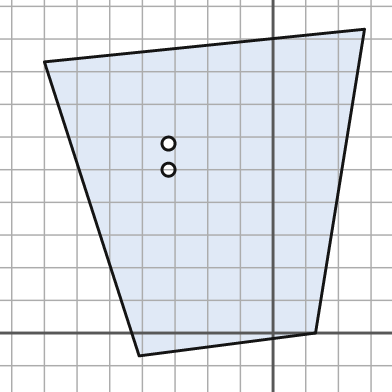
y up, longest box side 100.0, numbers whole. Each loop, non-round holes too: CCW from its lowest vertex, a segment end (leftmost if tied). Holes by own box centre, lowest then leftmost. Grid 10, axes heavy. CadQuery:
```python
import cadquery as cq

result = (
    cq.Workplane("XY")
    .moveTo(-41.0, -7.0)
    .lineTo(13.0, 0.0)
    .lineTo(28.0, 93.0)
    .lineTo(-70.0, 83.0)
    .close()
    .moveTo(-32.0, 50.0)
    .circle(2.0)
    .moveTo(-32.0, 58.0)
    .circle(2.0)
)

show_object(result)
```